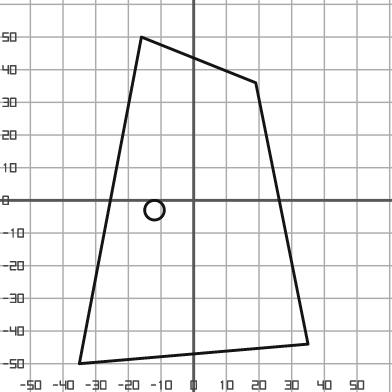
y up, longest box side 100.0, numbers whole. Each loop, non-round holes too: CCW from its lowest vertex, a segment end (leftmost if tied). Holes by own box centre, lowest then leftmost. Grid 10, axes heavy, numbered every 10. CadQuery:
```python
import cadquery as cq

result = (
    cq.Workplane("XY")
    .moveTo(-35.0, -50.0)
    .lineTo(35.0, -44.0)
    .lineTo(19.0, 36.0)
    .lineTo(-16.0, 50.0)
    .close()
    .moveTo(-12.0, -3.0)
    .circle(3.0)
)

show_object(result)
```